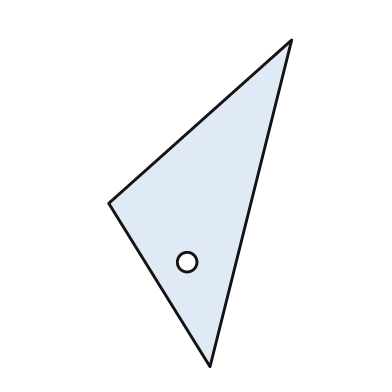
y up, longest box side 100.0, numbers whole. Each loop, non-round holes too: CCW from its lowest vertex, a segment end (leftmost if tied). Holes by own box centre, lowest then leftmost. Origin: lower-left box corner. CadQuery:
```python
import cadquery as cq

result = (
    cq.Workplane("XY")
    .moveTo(31.0, 0.0)
    .lineTo(56.0, 100.0)
    .lineTo(0.0, 50.0)
    .close()
    .moveTo(24.0, 32.0)
    .circle(3.0)
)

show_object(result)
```